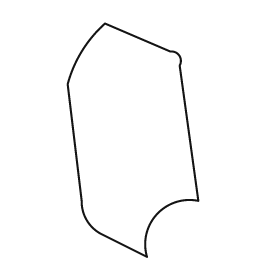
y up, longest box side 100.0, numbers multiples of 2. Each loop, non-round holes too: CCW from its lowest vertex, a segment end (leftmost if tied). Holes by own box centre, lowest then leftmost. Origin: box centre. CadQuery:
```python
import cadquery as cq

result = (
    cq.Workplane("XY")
    .moveTo(6.0, -50.0)
    .threePointArc((10.0, -32.0), (28.0, -26.0))
    .lineTo(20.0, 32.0)
    .threePointArc((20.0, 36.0), (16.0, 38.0))
    .lineTo(-12.0, 50.0)
    .threePointArc((-22.0, 38.0), (-28.0, 24.0))
    .lineTo(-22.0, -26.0)
    .threePointArc((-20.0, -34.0), (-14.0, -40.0))
    .close()
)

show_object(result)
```